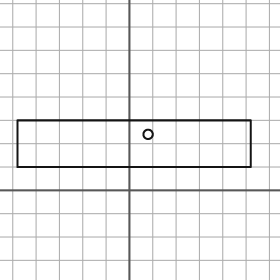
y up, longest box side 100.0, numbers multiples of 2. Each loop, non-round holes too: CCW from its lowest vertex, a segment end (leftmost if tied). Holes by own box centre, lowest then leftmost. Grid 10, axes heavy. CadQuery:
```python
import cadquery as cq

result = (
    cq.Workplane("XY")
    .moveTo(-48.0, 10.0)
    .lineTo(52.0, 10.0)
    .lineTo(52.0, 30.0)
    .lineTo(-48.0, 30.0)
    .close()
    .moveTo(8.0, 24.0)
    .circle(2.0)
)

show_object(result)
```